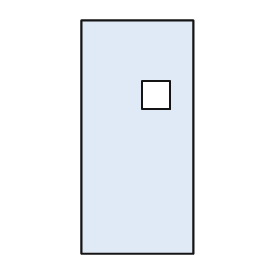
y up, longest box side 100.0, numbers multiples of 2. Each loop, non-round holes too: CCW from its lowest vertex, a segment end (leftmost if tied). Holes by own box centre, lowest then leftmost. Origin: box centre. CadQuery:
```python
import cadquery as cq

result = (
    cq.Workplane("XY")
    .moveTo(-24.0, -50.0)
    .lineTo(24.0, -50.0)
    .lineTo(24.0, 50.0)
    .lineTo(-24.0, 50.0)
    .close()
    .moveTo(2.0, 12.0)
    .lineTo(14.0, 12.0)
    .lineTo(14.0, 24.0)
    .lineTo(2.0, 24.0)
    .close()
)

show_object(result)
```